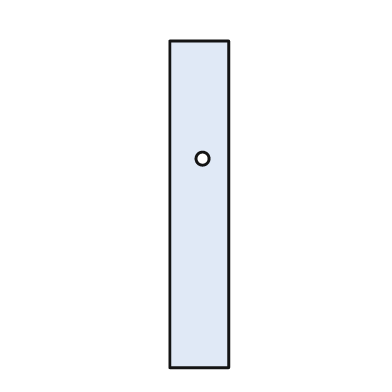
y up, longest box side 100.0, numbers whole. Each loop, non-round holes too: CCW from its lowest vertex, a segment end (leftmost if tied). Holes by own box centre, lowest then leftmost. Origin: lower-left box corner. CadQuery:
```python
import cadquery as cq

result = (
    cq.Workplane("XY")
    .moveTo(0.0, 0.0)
    .lineTo(18.0, 0.0)
    .lineTo(18.0, 100.0)
    .lineTo(0.0, 100.0)
    .close()
    .moveTo(10.0, 64.0)
    .circle(2.0)
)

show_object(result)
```